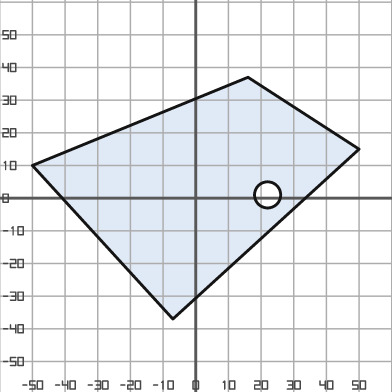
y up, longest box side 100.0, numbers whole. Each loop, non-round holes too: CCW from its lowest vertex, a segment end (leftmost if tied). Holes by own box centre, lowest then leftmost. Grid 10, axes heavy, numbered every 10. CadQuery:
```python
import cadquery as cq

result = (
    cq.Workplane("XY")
    .moveTo(-7.0, -37.0)
    .lineTo(50.0, 15.0)
    .lineTo(16.0, 37.0)
    .lineTo(-50.0, 10.0)
    .close()
    .moveTo(22.0, 1.0)
    .circle(4.0)
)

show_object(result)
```